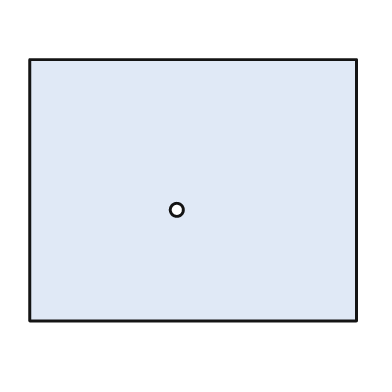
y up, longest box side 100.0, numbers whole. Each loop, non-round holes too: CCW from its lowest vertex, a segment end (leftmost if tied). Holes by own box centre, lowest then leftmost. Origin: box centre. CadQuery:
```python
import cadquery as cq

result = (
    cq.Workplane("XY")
    .moveTo(-50.0, -40.0)
    .lineTo(50.0, -40.0)
    .lineTo(50.0, 40.0)
    .lineTo(-50.0, 40.0)
    .close()
    .moveTo(-5.0, -6.0)
    .circle(2.0)
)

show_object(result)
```